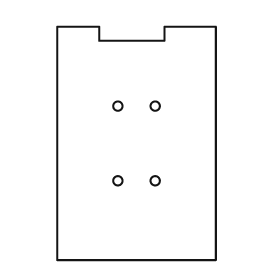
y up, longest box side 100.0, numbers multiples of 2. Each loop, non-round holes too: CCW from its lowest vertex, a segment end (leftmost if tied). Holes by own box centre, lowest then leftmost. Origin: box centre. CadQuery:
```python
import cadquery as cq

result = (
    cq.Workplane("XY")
    .moveTo(-34.0, -50.0)
    .lineTo(34.0, -50.0)
    .lineTo(34.0, 50.0)
    .lineTo(12.0, 50.0)
    .lineTo(12.0, 44.0)
    .lineTo(-16.0, 44.0)
    .lineTo(-16.0, 50.0)
    .lineTo(-34.0, 50.0)
    .close()
    .moveTo(-8.0, -16.0)
    .circle(2.0)
    .moveTo(8.0, -16.0)
    .circle(2.0)
    .moveTo(-8.0, 16.0)
    .circle(2.0)
    .moveTo(8.0, 16.0)
    .circle(2.0)
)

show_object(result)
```